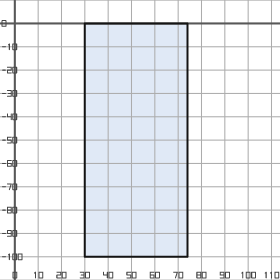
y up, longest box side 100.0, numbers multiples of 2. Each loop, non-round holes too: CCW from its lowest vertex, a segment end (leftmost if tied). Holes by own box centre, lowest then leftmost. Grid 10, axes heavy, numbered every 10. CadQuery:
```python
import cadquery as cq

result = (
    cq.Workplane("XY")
    .moveTo(30.0, -100.0)
    .lineTo(74.0, -100.0)
    .lineTo(74.0, 0.0)
    .lineTo(30.0, 0.0)
    .close()
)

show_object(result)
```